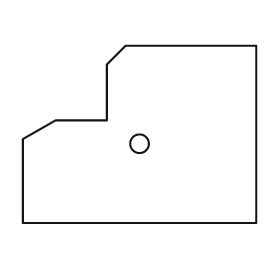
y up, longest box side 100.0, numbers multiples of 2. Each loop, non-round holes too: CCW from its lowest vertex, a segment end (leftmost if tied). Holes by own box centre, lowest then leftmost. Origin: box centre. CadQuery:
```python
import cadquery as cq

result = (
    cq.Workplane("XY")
    .moveTo(-50.0, -38.0)
    .lineTo(50.0, -38.0)
    .lineTo(50.0, 38.0)
    .lineTo(-6.0, 38.0)
    .lineTo(-14.0, 30.0)
    .lineTo(-14.0, 6.0)
    .lineTo(-36.0, 6.0)
    .lineTo(-50.0, -2.0)
    .close()
    .moveTo(0.0, -4.0)
    .circle(4.0)
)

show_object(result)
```